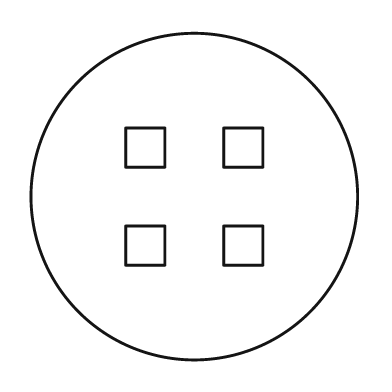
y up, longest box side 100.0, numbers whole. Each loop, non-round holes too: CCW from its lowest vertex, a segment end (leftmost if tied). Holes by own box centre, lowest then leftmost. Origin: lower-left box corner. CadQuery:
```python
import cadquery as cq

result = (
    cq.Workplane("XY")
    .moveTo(50.0, 50.0)
    .circle(50.0)
    .moveTo(29.0, 29.0)
    .lineTo(41.0, 29.0)
    .lineTo(41.0, 41.0)
    .lineTo(29.0, 41.0)
    .close()
    .moveTo(59.0, 29.0)
    .lineTo(71.0, 29.0)
    .lineTo(71.0, 41.0)
    .lineTo(59.0, 41.0)
    .close()
    .moveTo(29.0, 59.0)
    .lineTo(41.0, 59.0)
    .lineTo(41.0, 71.0)
    .lineTo(29.0, 71.0)
    .close()
    .moveTo(59.0, 59.0)
    .lineTo(71.0, 59.0)
    .lineTo(71.0, 71.0)
    .lineTo(59.0, 71.0)
    .close()
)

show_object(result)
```